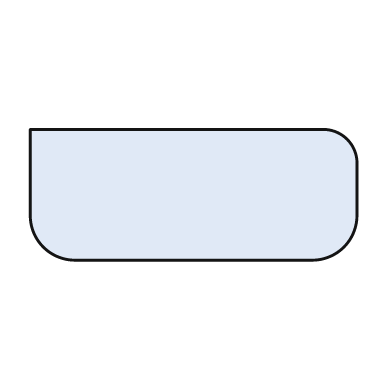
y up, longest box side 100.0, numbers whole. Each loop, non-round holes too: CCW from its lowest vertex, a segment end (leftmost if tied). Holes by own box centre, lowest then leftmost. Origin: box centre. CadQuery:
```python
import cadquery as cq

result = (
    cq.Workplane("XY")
    .moveTo(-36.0, -20.0)
    .lineTo(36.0, -20.0)
    .threePointArc((46.0, -16.0), (50.0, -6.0))
    .lineTo(50.0, 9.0)
    .threePointArc((47.0, 17.0), (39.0, 20.0))
    .lineTo(-50.0, 20.0)
    .lineTo(-50.0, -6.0)
    .threePointArc((-46.0, -16.0), (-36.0, -20.0))
    .close()
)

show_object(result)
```